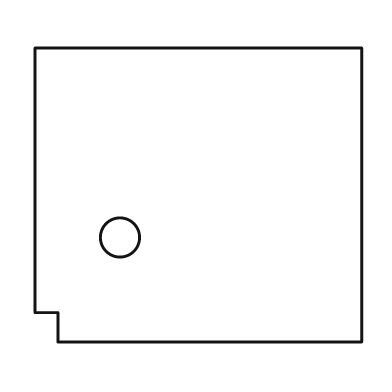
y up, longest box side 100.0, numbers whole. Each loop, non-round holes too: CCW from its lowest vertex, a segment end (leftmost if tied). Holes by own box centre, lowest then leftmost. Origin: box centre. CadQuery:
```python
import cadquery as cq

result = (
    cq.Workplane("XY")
    .moveTo(-43.0, -45.0)
    .lineTo(50.0, -45.0)
    .lineTo(50.0, 45.0)
    .lineTo(-50.0, 45.0)
    .lineTo(-50.0, -36.0)
    .lineTo(-43.0, -36.0)
    .close()
    .moveTo(-24.0, -13.0)
    .circle(6.0)
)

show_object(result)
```